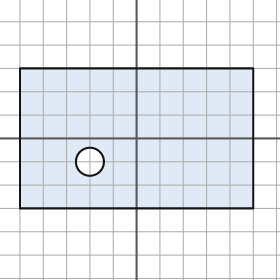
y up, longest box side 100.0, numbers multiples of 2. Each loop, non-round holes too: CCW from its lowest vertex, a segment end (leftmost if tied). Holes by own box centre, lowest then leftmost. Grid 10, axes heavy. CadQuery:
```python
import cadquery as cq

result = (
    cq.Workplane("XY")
    .moveTo(-50.0, -30.0)
    .lineTo(50.0, -30.0)
    .lineTo(50.0, 30.0)
    .lineTo(-50.0, 30.0)
    .close()
    .moveTo(-20.0, -10.0)
    .circle(6.0)
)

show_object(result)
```